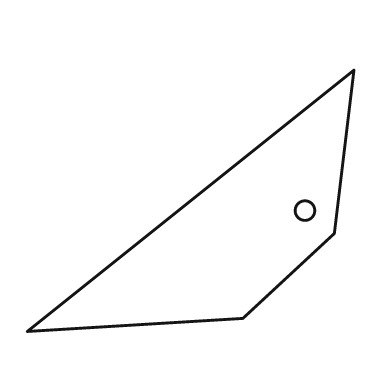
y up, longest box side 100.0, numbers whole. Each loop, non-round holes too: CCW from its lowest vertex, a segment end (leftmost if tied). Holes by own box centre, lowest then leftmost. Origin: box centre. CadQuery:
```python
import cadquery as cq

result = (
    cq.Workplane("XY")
    .moveTo(-50.0, -40.0)
    .lineTo(16.0, -36.0)
    .lineTo(44.0, -10.0)
    .lineTo(50.0, 40.0)
    .close()
    .moveTo(35.0, -3.0)
    .circle(3.0)
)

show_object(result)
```